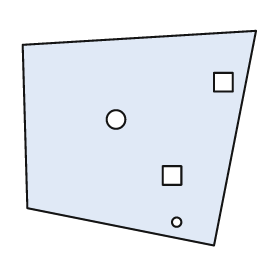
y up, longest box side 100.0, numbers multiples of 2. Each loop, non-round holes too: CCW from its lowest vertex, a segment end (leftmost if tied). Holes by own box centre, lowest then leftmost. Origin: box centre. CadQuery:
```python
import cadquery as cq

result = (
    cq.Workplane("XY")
    .moveTo(32.0, -46.0)
    .lineTo(50.0, 46.0)
    .lineTo(-50.0, 40.0)
    .lineTo(-48.0, -30.0)
    .close()
    .moveTo(16.0, -36.0)
    .circle(2.0)
    .moveTo(10.0, -20.0)
    .lineTo(18.0, -20.0)
    .lineTo(18.0, -12.0)
    .lineTo(10.0, -12.0)
    .close()
    .moveTo(-10.0, 8.0)
    .circle(4.0)
    .moveTo(32.0, 20.0)
    .lineTo(40.0, 20.0)
    .lineTo(40.0, 28.0)
    .lineTo(32.0, 28.0)
    .close()
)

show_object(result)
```